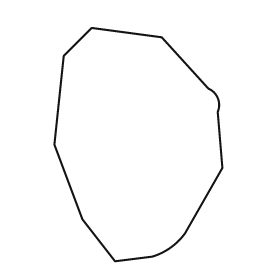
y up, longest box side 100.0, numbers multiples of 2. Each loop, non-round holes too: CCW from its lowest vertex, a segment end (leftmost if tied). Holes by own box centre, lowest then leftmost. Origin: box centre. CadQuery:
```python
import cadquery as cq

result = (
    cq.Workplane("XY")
    .moveTo(-10.0, -50.0)
    .lineTo(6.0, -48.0)
    .threePointArc((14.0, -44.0), (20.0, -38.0))
    .lineTo(36.0, -10.0)
    .lineTo(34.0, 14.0)
    .threePointArc((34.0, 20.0), (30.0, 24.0))
    .lineTo(10.0, 46.0)
    .lineTo(-20.0, 50.0)
    .lineTo(-32.0, 38.0)
    .lineTo(-36.0, 0.0)
    .lineTo(-24.0, -32.0)
    .close()
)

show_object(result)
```